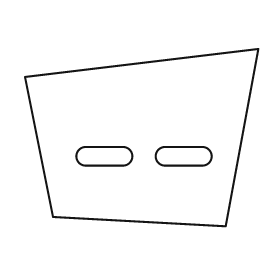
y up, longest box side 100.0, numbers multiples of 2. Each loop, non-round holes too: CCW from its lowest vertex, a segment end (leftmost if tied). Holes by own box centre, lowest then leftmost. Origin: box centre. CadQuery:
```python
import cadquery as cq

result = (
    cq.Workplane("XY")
    .moveTo(36.0, -38.0)
    .lineTo(50.0, 38.0)
    .lineTo(-50.0, 26.0)
    .lineTo(-38.0, -34.0)
    .close()
    .moveTo(-24.0, -12.0)
    .lineTo(-8.0, -12.0)
    .threePointArc((-4.0, -8.0), (-8.0, -4.0))
    .lineTo(-24.0, -4.0)
    .threePointArc((-28.0, -8.0), (-24.0, -12.0))
    .close()
    .moveTo(10.0, -12.0)
    .lineTo(26.0, -12.0)
    .threePointArc((30.0, -8.0), (26.0, -4.0))
    .lineTo(10.0, -4.0)
    .threePointArc((6.0, -8.0), (10.0, -12.0))
    .close()
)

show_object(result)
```